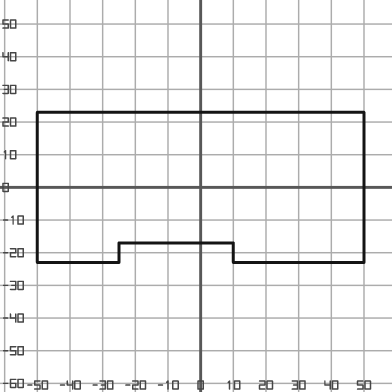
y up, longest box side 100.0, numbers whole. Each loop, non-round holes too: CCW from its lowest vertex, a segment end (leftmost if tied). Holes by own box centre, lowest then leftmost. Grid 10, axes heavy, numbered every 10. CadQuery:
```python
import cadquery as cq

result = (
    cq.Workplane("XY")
    .moveTo(-50.0, -23.0)
    .lineTo(-25.0, -23.0)
    .lineTo(-25.0, -17.0)
    .lineTo(10.0, -17.0)
    .lineTo(10.0, -23.0)
    .lineTo(50.0, -23.0)
    .lineTo(50.0, 23.0)
    .lineTo(-50.0, 23.0)
    .close()
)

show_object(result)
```